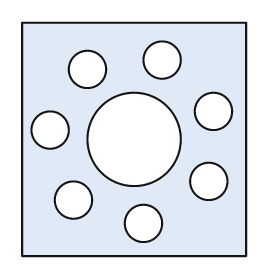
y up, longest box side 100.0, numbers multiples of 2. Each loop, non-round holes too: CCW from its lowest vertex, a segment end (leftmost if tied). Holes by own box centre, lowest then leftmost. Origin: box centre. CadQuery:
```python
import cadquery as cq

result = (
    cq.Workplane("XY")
    .moveTo(-48.0, -50.0)
    .lineTo(48.0, -50.0)
    .lineTo(48.0, 50.0)
    .lineTo(-48.0, 50.0)
    .close()
    .moveTo(4.0, -36.0)
    .circle(8.0)
    .moveTo(-26.0, -26.0)
    .circle(8.0)
    .moveTo(32.0, -18.0)
    .circle(8.0)
    .moveTo(0.0, 0.0)
    .circle(20.0)
    .moveTo(-36.0, 4.0)
    .circle(8.0)
    .moveTo(34.0, 12.0)
    .circle(8.0)
    .moveTo(-20.0, 30.0)
    .circle(8.0)
    .moveTo(12.0, 34.0)
    .circle(8.0)
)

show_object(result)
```